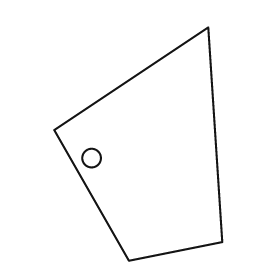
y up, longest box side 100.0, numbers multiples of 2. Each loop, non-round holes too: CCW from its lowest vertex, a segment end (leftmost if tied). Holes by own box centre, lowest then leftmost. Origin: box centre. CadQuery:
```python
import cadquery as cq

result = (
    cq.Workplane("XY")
    .moveTo(-4.0, -50.0)
    .lineTo(36.0, -42.0)
    .lineTo(30.0, 50.0)
    .lineTo(-36.0, 6.0)
    .close()
    .moveTo(-20.0, -6.0)
    .circle(4.0)
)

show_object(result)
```